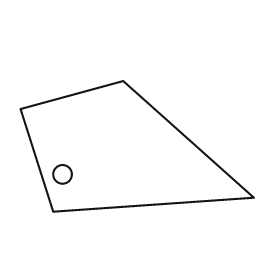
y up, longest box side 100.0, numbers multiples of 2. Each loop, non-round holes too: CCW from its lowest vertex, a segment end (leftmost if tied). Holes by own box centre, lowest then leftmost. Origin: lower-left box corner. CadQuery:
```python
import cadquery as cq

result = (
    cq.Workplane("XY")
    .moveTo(14.0, 0.0)
    .lineTo(100.0, 6.0)
    .lineTo(44.0, 56.0)
    .lineTo(0.0, 44.0)
    .close()
    .moveTo(18.0, 16.0)
    .circle(4.0)
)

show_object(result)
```